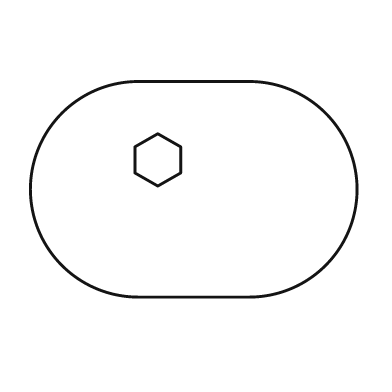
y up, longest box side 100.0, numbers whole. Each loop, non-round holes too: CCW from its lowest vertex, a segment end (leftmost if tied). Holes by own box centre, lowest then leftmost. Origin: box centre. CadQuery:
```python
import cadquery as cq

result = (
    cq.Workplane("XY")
    .moveTo(-17.0, -33.0)
    .lineTo(17.0, -33.0)
    .threePointArc((50.0, 0.0), (17.0, 33.0))
    .lineTo(-17.0, 33.0)
    .threePointArc((-50.0, 0.0), (-17.0, -33.0))
    .close()
    .moveTo(-11.0, 1.0)
    .lineTo(-4.0, 5.0)
    .lineTo(-4.0, 13.0)
    .lineTo(-11.0, 17.0)
    .lineTo(-18.0, 13.0)
    .lineTo(-18.0, 5.0)
    .close()
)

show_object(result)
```